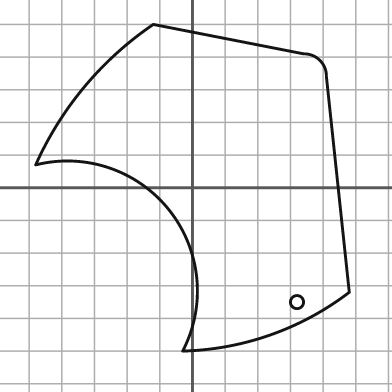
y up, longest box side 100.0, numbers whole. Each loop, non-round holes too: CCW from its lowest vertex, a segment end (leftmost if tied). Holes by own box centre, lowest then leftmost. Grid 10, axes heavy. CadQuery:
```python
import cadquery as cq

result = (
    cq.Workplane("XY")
    .moveTo(-3.0, -50.0)
    .threePointArc((24.0, -45.0), (48.0, -32.0))
    .lineTo(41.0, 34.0)
    .threePointArc((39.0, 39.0), (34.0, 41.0))
    .lineTo(-12.0, 50.0)
    .threePointArc((-33.0, 31.0), (-48.0, 7.0))
    .threePointArc((-7.0, -7.0), (-3.0, -50.0))
    .close()
    .moveTo(32.0, -35.0)
    .circle(2.0)
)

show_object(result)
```